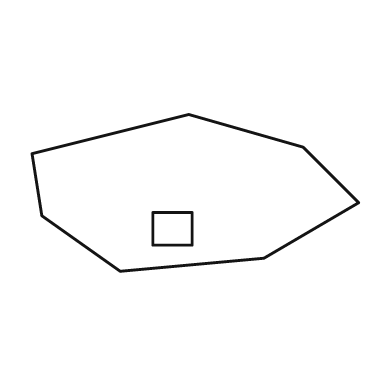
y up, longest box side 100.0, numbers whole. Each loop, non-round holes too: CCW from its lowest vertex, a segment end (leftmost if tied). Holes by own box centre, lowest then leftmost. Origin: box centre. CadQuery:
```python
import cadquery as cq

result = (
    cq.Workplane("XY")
    .moveTo(-23.0, -24.0)
    .lineTo(21.0, -20.0)
    .lineTo(50.0, -3.0)
    .lineTo(33.0, 14.0)
    .lineTo(-2.0, 24.0)
    .lineTo(-50.0, 12.0)
    .lineTo(-47.0, -7.0)
    .close()
    .moveTo(-13.0, -16.0)
    .lineTo(-1.0, -16.0)
    .lineTo(-1.0, -6.0)
    .lineTo(-13.0, -6.0)
    .close()
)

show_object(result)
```